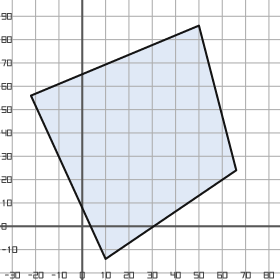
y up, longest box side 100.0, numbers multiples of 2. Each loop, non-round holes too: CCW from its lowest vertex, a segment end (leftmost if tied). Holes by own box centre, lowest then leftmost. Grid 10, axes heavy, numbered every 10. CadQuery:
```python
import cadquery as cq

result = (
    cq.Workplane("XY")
    .moveTo(10.0, -14.0)
    .lineTo(66.0, 24.0)
    .lineTo(50.0, 86.0)
    .lineTo(-22.0, 56.0)
    .close()
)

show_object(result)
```